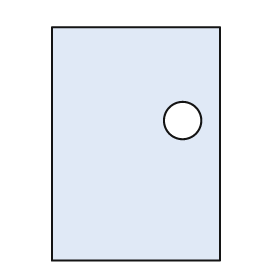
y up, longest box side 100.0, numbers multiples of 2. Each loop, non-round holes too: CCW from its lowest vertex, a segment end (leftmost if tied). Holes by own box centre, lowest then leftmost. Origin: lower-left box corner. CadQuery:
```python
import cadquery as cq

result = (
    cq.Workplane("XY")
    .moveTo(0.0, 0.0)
    .lineTo(72.0, 0.0)
    .lineTo(72.0, 100.0)
    .lineTo(0.0, 100.0)
    .close()
    .moveTo(56.0, 60.0)
    .circle(8.0)
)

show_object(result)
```